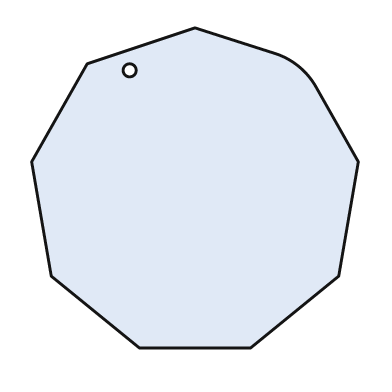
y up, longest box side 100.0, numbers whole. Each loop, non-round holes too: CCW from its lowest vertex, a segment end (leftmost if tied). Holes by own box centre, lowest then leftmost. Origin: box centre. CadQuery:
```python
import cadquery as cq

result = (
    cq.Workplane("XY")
    .moveTo(-17.0, -49.0)
    .lineTo(17.0, -49.0)
    .lineTo(44.0, -27.0)
    .lineTo(50.0, 8.0)
    .lineTo(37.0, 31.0)
    .threePointArc((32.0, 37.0), (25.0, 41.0))
    .lineTo(0.0, 49.0)
    .lineTo(-33.0, 38.0)
    .lineTo(-50.0, 8.0)
    .lineTo(-44.0, -27.0)
    .close()
    .moveTo(-20.0, 36.0)
    .circle(2.0)
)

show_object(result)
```